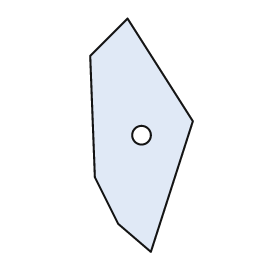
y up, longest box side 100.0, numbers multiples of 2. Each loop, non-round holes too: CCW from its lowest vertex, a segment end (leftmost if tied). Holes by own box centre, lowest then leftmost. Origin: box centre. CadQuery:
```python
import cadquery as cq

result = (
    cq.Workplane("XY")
    .moveTo(4.0, -50.0)
    .lineTo(22.0, 6.0)
    .lineTo(-6.0, 50.0)
    .lineTo(-22.0, 34.0)
    .lineTo(-20.0, -18.0)
    .lineTo(-10.0, -38.0)
    .close()
    .moveTo(0.0, 0.0)
    .circle(4.0)
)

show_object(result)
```